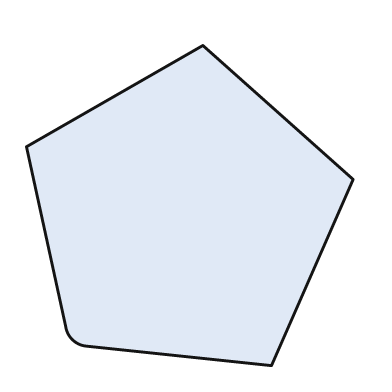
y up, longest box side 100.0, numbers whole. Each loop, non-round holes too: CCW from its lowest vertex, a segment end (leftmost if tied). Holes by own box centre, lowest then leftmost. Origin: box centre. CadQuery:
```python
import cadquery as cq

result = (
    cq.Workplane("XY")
    .moveTo(25.0, -49.0)
    .lineTo(50.0, 8.0)
    .lineTo(4.0, 49.0)
    .lineTo(-50.0, 18.0)
    .lineTo(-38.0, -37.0)
    .threePointArc((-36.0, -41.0), (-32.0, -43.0))
    .close()
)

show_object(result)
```